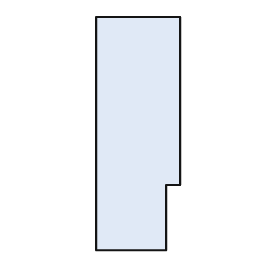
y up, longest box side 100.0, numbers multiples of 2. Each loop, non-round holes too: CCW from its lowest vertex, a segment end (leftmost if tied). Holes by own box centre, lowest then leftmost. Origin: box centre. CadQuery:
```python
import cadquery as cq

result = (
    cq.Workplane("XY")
    .moveTo(-18.0, -50.0)
    .lineTo(12.0, -50.0)
    .lineTo(12.0, -22.0)
    .lineTo(18.0, -22.0)
    .lineTo(18.0, 50.0)
    .lineTo(-18.0, 50.0)
    .close()
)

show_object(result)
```